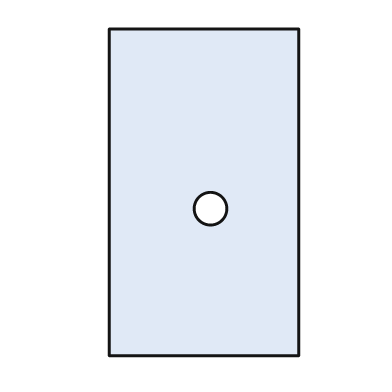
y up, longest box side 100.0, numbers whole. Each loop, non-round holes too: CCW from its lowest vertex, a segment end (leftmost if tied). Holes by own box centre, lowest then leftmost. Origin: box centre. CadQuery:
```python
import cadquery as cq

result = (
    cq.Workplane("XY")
    .moveTo(-29.0, -50.0)
    .lineTo(29.0, -50.0)
    .lineTo(29.0, 50.0)
    .lineTo(-29.0, 50.0)
    .close()
    .moveTo(2.0, -5.0)
    .circle(5.0)
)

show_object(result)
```